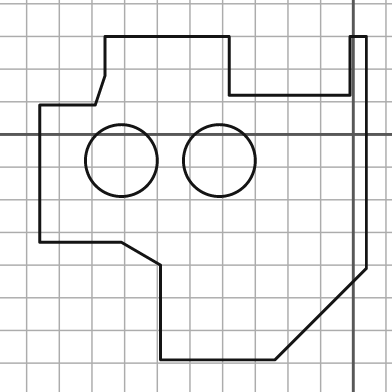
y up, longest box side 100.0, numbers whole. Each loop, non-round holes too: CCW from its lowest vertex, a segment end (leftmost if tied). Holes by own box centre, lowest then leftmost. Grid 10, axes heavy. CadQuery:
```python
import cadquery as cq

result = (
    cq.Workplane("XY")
    .moveTo(-59.0, -69.0)
    .lineTo(-24.0, -69.0)
    .lineTo(4.0, -41.0)
    .lineTo(4.0, 30.0)
    .lineTo(-1.0, 30.0)
    .lineTo(-1.0, 12.0)
    .lineTo(-38.0, 12.0)
    .lineTo(-38.0, 30.0)
    .lineTo(-76.0, 30.0)
    .lineTo(-76.0, 18.0)
    .lineTo(-79.0, 9.0)
    .lineTo(-96.0, 9.0)
    .lineTo(-96.0, -33.0)
    .lineTo(-71.0, -33.0)
    .lineTo(-59.0, -40.0)
    .close()
    .moveTo(-71.0, -8.0)
    .circle(11.0)
    .moveTo(-41.0, -8.0)
    .circle(11.0)
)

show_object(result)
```